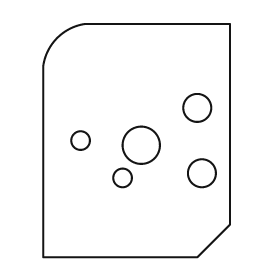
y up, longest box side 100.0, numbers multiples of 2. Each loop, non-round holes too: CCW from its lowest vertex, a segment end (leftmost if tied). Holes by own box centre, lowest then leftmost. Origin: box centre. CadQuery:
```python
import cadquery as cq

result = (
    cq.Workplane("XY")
    .moveTo(-40.0, -50.0)
    .lineTo(26.0, -50.0)
    .lineTo(40.0, -36.0)
    .lineTo(40.0, 50.0)
    .lineTo(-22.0, 50.0)
    .threePointArc((-34.0, 44.0), (-40.0, 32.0))
    .close()
    .moveTo(-6.0, -16.0)
    .circle(4.0)
    .moveTo(28.0, -14.0)
    .circle(6.0)
    .moveTo(2.0, -2.0)
    .circle(8.0)
    .moveTo(-24.0, 0.0)
    .circle(4.0)
    .moveTo(26.0, 14.0)
    .circle(6.0)
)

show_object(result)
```